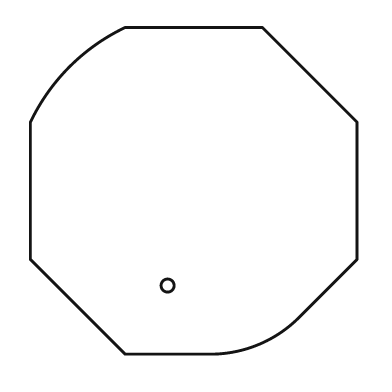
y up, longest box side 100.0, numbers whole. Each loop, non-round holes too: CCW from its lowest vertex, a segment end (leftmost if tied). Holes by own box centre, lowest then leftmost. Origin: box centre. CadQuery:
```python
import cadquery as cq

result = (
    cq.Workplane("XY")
    .moveTo(-21.0, -50.0)
    .lineTo(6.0, -50.0)
    .threePointArc((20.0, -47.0), (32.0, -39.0))
    .lineTo(50.0, -21.0)
    .lineTo(50.0, 21.0)
    .lineTo(21.0, 50.0)
    .lineTo(-21.0, 50.0)
    .threePointArc((-38.0, 38.0), (-50.0, 21.0))
    .lineTo(-50.0, -21.0)
    .close()
    .moveTo(-8.0, -29.0)
    .circle(2.0)
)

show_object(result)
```